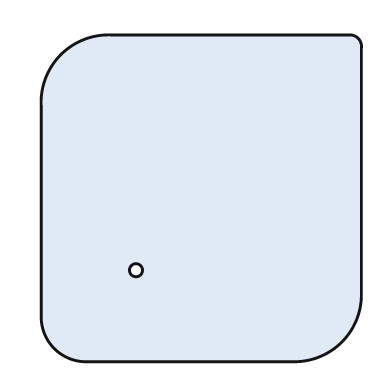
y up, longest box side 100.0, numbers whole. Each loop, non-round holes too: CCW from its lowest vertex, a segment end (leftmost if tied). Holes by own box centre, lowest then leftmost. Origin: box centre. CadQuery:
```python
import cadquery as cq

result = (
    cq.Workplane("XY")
    .moveTo(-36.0, -50.0)
    .lineTo(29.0, -50.0)
    .threePointArc((43.0, -44.0), (49.0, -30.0))
    .lineTo(49.0, 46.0)
    .threePointArc((48.0, 49.0), (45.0, 50.0))
    .lineTo(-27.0, 50.0)
    .threePointArc((-43.0, 44.0), (-49.0, 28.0))
    .lineTo(-49.0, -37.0)
    .threePointArc((-45.0, -46.0), (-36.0, -50.0))
    .close()
    .moveTo(-20.0, -22.0)
    .circle(2.0)
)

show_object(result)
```